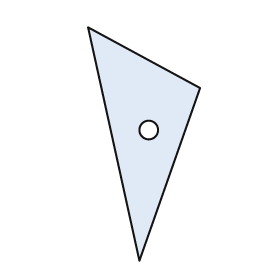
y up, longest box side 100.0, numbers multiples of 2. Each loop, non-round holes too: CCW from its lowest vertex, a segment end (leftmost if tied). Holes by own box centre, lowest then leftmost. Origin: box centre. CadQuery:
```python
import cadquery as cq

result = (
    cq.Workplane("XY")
    .moveTo(-2.0, -50.0)
    .lineTo(24.0, 24.0)
    .lineTo(-24.0, 50.0)
    .close()
    .moveTo(2.0, 6.0)
    .circle(4.0)
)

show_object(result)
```